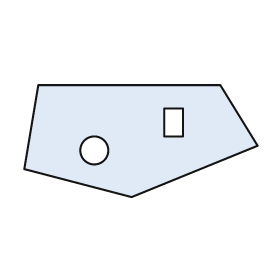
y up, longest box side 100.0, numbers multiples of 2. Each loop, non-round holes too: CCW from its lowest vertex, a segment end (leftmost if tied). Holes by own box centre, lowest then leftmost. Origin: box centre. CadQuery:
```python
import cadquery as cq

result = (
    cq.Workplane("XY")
    .moveTo(-4.0, -24.0)
    .lineTo(50.0, -2.0)
    .lineTo(34.0, 24.0)
    .lineTo(-44.0, 24.0)
    .lineTo(-50.0, -12.0)
    .close()
    .moveTo(-20.0, -4.0)
    .circle(6.0)
    .moveTo(10.0, 2.0)
    .lineTo(18.0, 2.0)
    .lineTo(18.0, 14.0)
    .lineTo(10.0, 14.0)
    .close()
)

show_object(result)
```